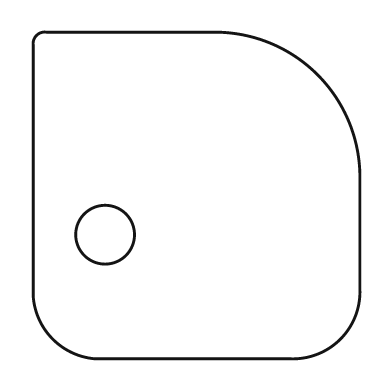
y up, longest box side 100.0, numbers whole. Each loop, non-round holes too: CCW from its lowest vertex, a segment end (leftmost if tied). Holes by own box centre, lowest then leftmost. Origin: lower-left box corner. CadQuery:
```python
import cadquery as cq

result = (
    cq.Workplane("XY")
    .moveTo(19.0, 0.0)
    .lineTo(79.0, 0.0)
    .threePointArc((94.0, 6.0), (100.0, 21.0))
    .lineTo(100.0, 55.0)
    .threePointArc((87.0, 87.0), (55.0, 100.0))
    .lineTo(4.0, 100.0)
    .threePointArc((1.0, 99.0), (0.0, 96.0))
    .lineTo(0.0, 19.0)
    .threePointArc((6.0, 6.0), (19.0, 0.0))
    .close()
    .moveTo(22.0, 38.0)
    .circle(9.0)
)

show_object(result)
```